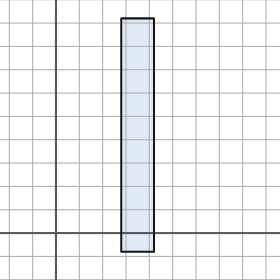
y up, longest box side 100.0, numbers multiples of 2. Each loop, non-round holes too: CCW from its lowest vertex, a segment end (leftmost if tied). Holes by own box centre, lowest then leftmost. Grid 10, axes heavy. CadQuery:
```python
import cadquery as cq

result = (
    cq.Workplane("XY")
    .moveTo(28.0, -8.0)
    .lineTo(42.0, -8.0)
    .lineTo(42.0, 92.0)
    .lineTo(28.0, 92.0)
    .close()
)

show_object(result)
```